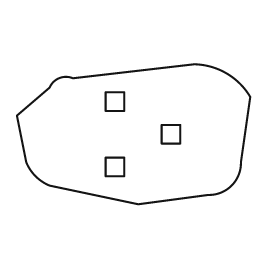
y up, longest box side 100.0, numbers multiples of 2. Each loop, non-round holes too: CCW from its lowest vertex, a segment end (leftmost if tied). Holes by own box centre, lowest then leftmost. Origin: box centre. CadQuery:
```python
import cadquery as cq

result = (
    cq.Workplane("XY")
    .moveTo(2.0, -30.0)
    .lineTo(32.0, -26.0)
    .threePointArc((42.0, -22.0), (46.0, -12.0))
    .lineTo(50.0, 16.0)
    .threePointArc((40.0, 26.0), (26.0, 30.0))
    .lineTo(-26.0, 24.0)
    .threePointArc((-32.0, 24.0), (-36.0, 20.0))
    .lineTo(-50.0, 8.0)
    .lineTo(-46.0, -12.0)
    .threePointArc((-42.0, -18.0), (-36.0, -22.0))
    .close()
    .moveTo(-12.0, -18.0)
    .lineTo(-4.0, -18.0)
    .lineTo(-4.0, -10.0)
    .lineTo(-12.0, -10.0)
    .close()
    .moveTo(12.0, -4.0)
    .lineTo(20.0, -4.0)
    .lineTo(20.0, 4.0)
    .lineTo(12.0, 4.0)
    .close()
    .moveTo(-12.0, 10.0)
    .lineTo(-4.0, 10.0)
    .lineTo(-4.0, 18.0)
    .lineTo(-12.0, 18.0)
    .close()
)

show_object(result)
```